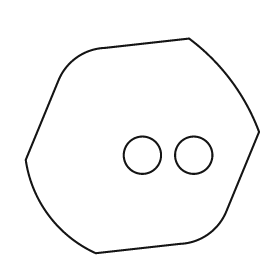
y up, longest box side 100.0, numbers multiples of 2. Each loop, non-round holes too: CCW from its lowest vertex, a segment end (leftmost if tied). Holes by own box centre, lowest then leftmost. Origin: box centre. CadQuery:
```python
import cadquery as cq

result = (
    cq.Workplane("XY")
    .moveTo(-20.0, -46.0)
    .lineTo(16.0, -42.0)
    .threePointArc((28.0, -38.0), (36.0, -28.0))
    .lineTo(50.0, 6.0)
    .threePointArc((38.0, 28.0), (20.0, 46.0))
    .lineTo(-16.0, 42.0)
    .threePointArc((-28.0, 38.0), (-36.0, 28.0))
    .lineTo(-50.0, -6.0)
    .threePointArc((-40.0, -30.0), (-20.0, -46.0))
    .close()
    .moveTo(0.0, -4.0)
    .circle(8.0)
    .moveTo(22.0, -4.0)
    .circle(8.0)
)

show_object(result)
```